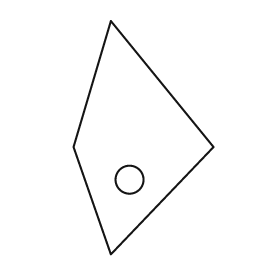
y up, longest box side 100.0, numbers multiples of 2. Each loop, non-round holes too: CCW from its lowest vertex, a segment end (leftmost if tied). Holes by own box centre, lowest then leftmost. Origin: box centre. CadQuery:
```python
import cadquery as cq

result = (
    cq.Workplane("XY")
    .moveTo(-14.0, -50.0)
    .lineTo(30.0, -4.0)
    .lineTo(-14.0, 50.0)
    .lineTo(-30.0, -4.0)
    .close()
    .moveTo(-6.0, -18.0)
    .circle(6.0)
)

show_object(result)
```